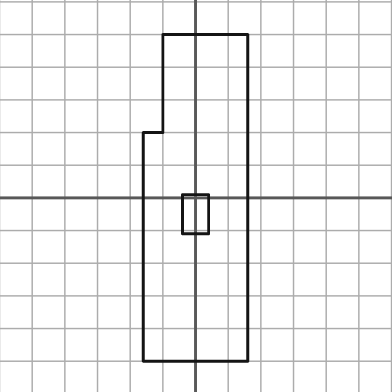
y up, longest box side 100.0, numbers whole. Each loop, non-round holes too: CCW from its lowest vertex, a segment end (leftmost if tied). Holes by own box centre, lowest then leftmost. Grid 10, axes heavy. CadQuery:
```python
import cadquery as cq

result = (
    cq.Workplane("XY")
    .moveTo(-16.0, -50.0)
    .lineTo(16.0, -50.0)
    .lineTo(16.0, 50.0)
    .lineTo(-10.0, 50.0)
    .lineTo(-10.0, 20.0)
    .lineTo(-16.0, 20.0)
    .close()
    .moveTo(-4.0, -11.0)
    .lineTo(4.0, -11.0)
    .lineTo(4.0, 1.0)
    .lineTo(-4.0, 1.0)
    .close()
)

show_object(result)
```